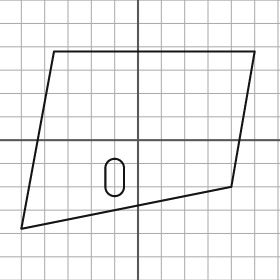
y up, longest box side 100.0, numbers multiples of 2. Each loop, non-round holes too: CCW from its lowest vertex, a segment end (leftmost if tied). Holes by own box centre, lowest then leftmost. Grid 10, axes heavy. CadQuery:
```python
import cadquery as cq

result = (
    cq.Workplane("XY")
    .moveTo(-50.0, -38.0)
    .lineTo(40.0, -20.0)
    .lineTo(50.0, 38.0)
    .lineTo(-36.0, 38.0)
    .close()
    .moveTo(-14.0, -20.0)
    .threePointArc((-10.0, -24.0), (-6.0, -20.0))
    .lineTo(-6.0, -12.0)
    .threePointArc((-10.0, -8.0), (-14.0, -12.0))
    .close()
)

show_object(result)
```